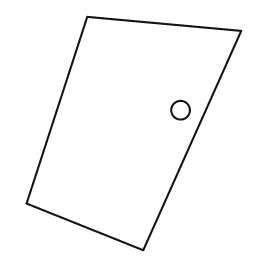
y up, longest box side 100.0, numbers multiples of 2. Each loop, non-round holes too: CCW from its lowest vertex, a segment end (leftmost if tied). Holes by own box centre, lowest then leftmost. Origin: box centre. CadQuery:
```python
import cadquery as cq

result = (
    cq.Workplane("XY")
    .moveTo(4.0, -50.0)
    .lineTo(46.0, 44.0)
    .lineTo(-20.0, 50.0)
    .lineTo(-46.0, -30.0)
    .close()
    .moveTo(20.0, 10.0)
    .circle(4.0)
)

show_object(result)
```